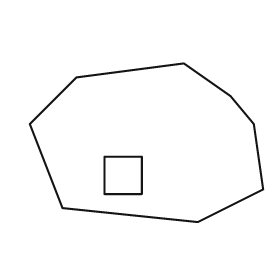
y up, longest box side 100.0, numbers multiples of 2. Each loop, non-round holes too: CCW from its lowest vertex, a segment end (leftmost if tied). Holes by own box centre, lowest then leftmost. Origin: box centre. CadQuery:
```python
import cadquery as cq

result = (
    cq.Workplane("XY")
    .moveTo(22.0, -34.0)
    .lineTo(50.0, -20.0)
    .lineTo(46.0, 8.0)
    .lineTo(36.0, 20.0)
    .lineTo(16.0, 34.0)
    .lineTo(-30.0, 28.0)
    .lineTo(-50.0, 8.0)
    .lineTo(-36.0, -28.0)
    .close()
    .moveTo(-18.0, -22.0)
    .lineTo(-2.0, -22.0)
    .lineTo(-2.0, -6.0)
    .lineTo(-18.0, -6.0)
    .close()
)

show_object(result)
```